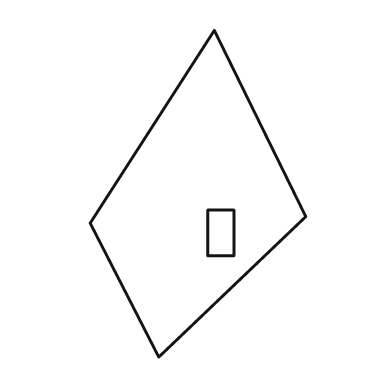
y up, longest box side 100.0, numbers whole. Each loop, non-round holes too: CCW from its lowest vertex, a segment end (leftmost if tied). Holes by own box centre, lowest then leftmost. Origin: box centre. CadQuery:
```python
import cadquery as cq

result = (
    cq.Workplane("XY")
    .moveTo(-12.0, -50.0)
    .lineTo(33.0, -7.0)
    .lineTo(5.0, 50.0)
    .lineTo(-33.0, -9.0)
    .close()
    .moveTo(3.0, -19.0)
    .lineTo(11.0, -19.0)
    .lineTo(11.0, -5.0)
    .lineTo(3.0, -5.0)
    .close()
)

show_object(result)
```